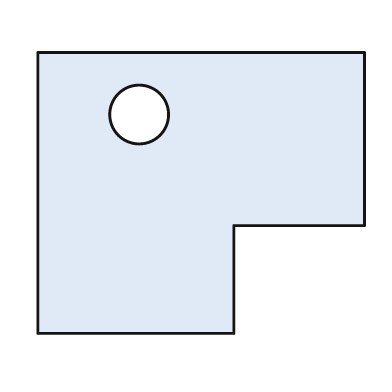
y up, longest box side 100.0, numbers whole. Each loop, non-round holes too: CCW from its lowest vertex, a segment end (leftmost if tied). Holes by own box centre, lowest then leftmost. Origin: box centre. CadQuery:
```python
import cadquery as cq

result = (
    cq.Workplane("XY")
    .moveTo(-50.0, -43.0)
    .lineTo(10.0, -43.0)
    .lineTo(10.0, -10.0)
    .lineTo(50.0, -10.0)
    .lineTo(50.0, 43.0)
    .lineTo(-50.0, 43.0)
    .close()
    .moveTo(-19.0, 24.0)
    .circle(9.0)
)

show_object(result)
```